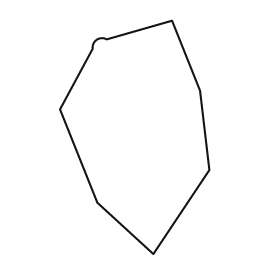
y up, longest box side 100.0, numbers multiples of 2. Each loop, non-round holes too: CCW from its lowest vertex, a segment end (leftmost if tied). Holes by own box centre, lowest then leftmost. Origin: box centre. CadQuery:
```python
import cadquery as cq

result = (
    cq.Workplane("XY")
    .moveTo(8.0, -50.0)
    .lineTo(32.0, -14.0)
    .lineTo(28.0, 20.0)
    .lineTo(16.0, 50.0)
    .lineTo(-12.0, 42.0)
    .threePointArc((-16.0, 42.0), (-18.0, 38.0))
    .lineTo(-32.0, 12.0)
    .lineTo(-16.0, -28.0)
    .close()
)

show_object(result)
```